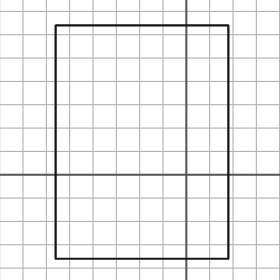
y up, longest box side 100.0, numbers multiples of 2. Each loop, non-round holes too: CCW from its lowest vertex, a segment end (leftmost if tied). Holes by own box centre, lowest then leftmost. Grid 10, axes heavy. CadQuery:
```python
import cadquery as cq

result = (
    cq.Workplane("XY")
    .moveTo(-56.0, -36.0)
    .lineTo(18.0, -36.0)
    .lineTo(18.0, 64.0)
    .lineTo(-56.0, 64.0)
    .close()
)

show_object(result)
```